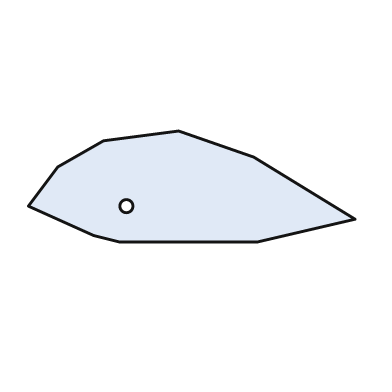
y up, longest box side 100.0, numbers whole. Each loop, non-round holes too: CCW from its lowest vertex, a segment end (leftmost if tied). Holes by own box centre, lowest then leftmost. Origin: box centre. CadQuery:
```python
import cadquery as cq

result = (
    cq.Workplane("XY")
    .moveTo(-22.0, -17.0)
    .lineTo(20.0, -17.0)
    .lineTo(50.0, -10.0)
    .lineTo(19.0, 9.0)
    .lineTo(-4.0, 17.0)
    .lineTo(-27.0, 14.0)
    .lineTo(-41.0, 6.0)
    .lineTo(-50.0, -6.0)
    .lineTo(-30.0, -15.0)
    .close()
    .moveTo(-20.0, -6.0)
    .circle(2.0)
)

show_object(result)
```